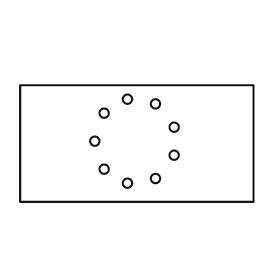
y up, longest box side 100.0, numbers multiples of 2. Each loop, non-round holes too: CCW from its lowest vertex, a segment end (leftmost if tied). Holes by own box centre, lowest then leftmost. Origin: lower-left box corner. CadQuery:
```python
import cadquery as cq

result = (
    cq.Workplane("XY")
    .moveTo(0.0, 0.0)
    .lineTo(100.0, 0.0)
    .lineTo(100.0, 50.0)
    .lineTo(0.0, 50.0)
    .close()
    .moveTo(46.0, 8.0)
    .circle(2.0)
    .moveTo(58.0, 10.0)
    .circle(2.0)
    .moveTo(36.0, 14.0)
    .circle(2.0)
    .moveTo(66.0, 20.0)
    .circle(2.0)
    .moveTo(32.0, 26.0)
    .circle(2.0)
    .moveTo(66.0, 32.0)
    .circle(2.0)
    .moveTo(36.0, 38.0)
    .circle(2.0)
    .moveTo(58.0, 42.0)
    .circle(2.0)
    .moveTo(46.0, 44.0)
    .circle(2.0)
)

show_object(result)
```